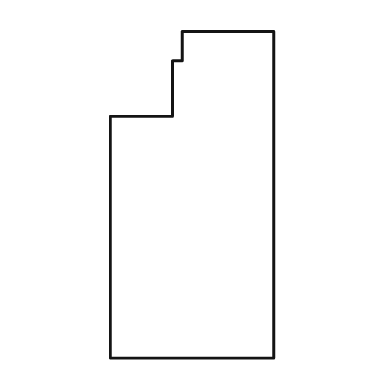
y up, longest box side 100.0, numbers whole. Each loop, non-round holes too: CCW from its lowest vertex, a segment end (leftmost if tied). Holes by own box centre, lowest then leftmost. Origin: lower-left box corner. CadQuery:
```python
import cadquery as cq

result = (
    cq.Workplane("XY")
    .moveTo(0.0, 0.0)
    .lineTo(50.0, 0.0)
    .lineTo(50.0, 100.0)
    .lineTo(22.0, 100.0)
    .lineTo(22.0, 91.0)
    .lineTo(19.0, 91.0)
    .lineTo(19.0, 74.0)
    .lineTo(0.0, 74.0)
    .close()
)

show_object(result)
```